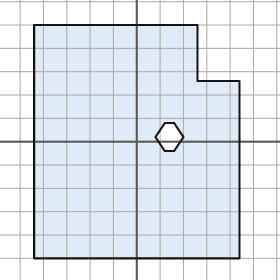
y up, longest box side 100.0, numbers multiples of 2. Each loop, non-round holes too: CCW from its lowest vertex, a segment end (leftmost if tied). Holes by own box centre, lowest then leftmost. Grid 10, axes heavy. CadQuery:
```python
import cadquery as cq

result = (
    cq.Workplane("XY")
    .moveTo(-44.0, -50.0)
    .lineTo(44.0, -50.0)
    .lineTo(44.0, 26.0)
    .lineTo(26.0, 26.0)
    .lineTo(26.0, 50.0)
    .lineTo(-44.0, 50.0)
    .close()
    .moveTo(12.0, -4.0)
    .lineTo(16.0, -4.0)
    .lineTo(20.0, 2.0)
    .lineTo(16.0, 8.0)
    .lineTo(12.0, 8.0)
    .lineTo(8.0, 2.0)
    .close()
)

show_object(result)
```